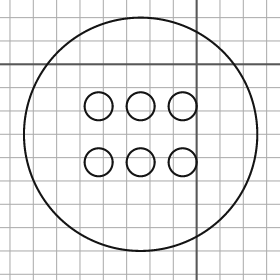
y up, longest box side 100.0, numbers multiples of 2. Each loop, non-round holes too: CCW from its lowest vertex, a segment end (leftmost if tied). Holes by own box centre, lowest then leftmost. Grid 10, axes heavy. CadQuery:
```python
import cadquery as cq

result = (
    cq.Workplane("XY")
    .moveTo(-24.0, -30.0)
    .circle(50.0)
    .moveTo(-42.0, -42.0)
    .circle(6.0)
    .moveTo(-24.0, -42.0)
    .circle(6.0)
    .moveTo(-6.0, -42.0)
    .circle(6.0)
    .moveTo(-42.0, -18.0)
    .circle(6.0)
    .moveTo(-24.0, -18.0)
    .circle(6.0)
    .moveTo(-6.0, -18.0)
    .circle(6.0)
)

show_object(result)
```